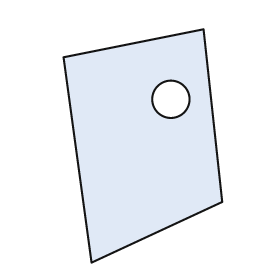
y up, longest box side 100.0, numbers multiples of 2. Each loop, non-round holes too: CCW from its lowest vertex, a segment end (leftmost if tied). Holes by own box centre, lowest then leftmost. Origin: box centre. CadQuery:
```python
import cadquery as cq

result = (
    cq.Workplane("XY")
    .moveTo(-22.0, -50.0)
    .lineTo(34.0, -24.0)
    .lineTo(26.0, 50.0)
    .lineTo(-34.0, 38.0)
    .close()
    .moveTo(12.0, 20.0)
    .circle(8.0)
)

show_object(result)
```